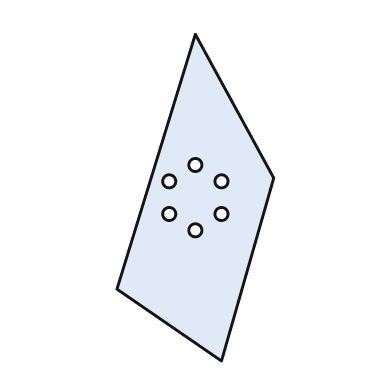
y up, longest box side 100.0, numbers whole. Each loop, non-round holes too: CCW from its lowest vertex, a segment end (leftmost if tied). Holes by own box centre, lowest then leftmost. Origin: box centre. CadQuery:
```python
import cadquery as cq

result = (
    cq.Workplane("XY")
    .moveTo(8.0, -50.0)
    .lineTo(24.0, 6.0)
    .lineTo(0.0, 50.0)
    .lineTo(-24.0, -28.0)
    .close()
    .moveTo(0.0, -10.0)
    .circle(2.0)
    .moveTo(-8.0, -5.0)
    .circle(2.0)
    .moveTo(8.0, -5.0)
    .circle(2.0)
    .moveTo(-8.0, 5.0)
    .circle(2.0)
    .moveTo(8.0, 5.0)
    .circle(2.0)
    .moveTo(0.0, 10.0)
    .circle(2.0)
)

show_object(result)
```